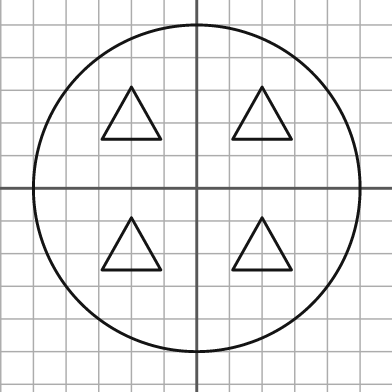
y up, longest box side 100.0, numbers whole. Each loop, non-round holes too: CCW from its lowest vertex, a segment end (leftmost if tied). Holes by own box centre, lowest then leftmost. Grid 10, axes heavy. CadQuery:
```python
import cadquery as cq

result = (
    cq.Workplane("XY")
    .moveTo(0.0, 0.0)
    .circle(50.0)
    .moveTo(-29.0, -25.0)
    .lineTo(-11.0, -25.0)
    .lineTo(-20.0, -9.0)
    .close()
    .moveTo(11.0, -25.0)
    .lineTo(29.0, -25.0)
    .lineTo(20.0, -9.0)
    .close()
    .moveTo(-29.0, 15.0)
    .lineTo(-11.0, 15.0)
    .lineTo(-20.0, 31.0)
    .close()
    .moveTo(11.0, 15.0)
    .lineTo(29.0, 15.0)
    .lineTo(20.0, 31.0)
    .close()
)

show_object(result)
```